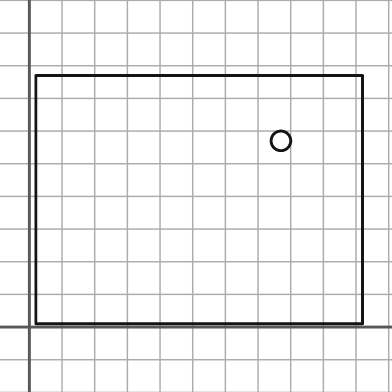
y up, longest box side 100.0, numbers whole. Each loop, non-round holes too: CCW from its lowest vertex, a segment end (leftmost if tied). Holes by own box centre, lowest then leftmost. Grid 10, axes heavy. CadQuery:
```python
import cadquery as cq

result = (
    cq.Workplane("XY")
    .moveTo(2.0, 1.0)
    .lineTo(102.0, 1.0)
    .lineTo(102.0, 77.0)
    .lineTo(2.0, 77.0)
    .close()
    .moveTo(77.0, 57.0)
    .circle(3.0)
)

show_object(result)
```